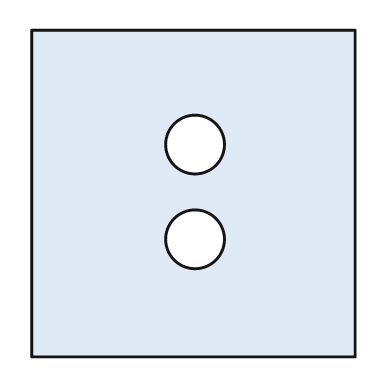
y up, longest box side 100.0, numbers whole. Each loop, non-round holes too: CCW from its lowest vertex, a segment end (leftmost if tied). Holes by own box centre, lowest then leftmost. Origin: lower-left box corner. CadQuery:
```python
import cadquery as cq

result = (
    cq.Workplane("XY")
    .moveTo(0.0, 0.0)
    .lineTo(99.0, 0.0)
    .lineTo(99.0, 100.0)
    .lineTo(0.0, 100.0)
    .close()
    .moveTo(50.0, 36.0)
    .circle(9.0)
    .moveTo(50.0, 65.0)
    .circle(9.0)
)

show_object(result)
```